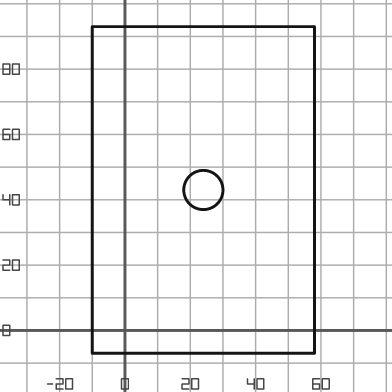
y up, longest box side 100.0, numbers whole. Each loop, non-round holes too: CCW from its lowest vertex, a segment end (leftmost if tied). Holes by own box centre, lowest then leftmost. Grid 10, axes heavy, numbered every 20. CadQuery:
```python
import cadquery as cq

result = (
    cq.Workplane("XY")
    .moveTo(-10.0, -7.0)
    .lineTo(58.0, -7.0)
    .lineTo(58.0, 93.0)
    .lineTo(-10.0, 93.0)
    .close()
    .moveTo(24.0, 43.0)
    .circle(6.0)
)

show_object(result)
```